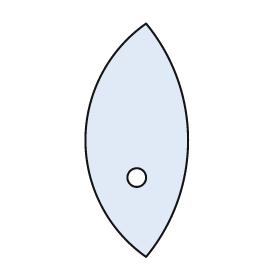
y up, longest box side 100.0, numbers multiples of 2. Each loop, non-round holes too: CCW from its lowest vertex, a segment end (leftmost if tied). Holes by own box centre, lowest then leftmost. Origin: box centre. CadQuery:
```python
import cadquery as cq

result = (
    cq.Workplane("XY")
    .moveTo(4.0, -50.0)
    .threePointArc((22.0, 0.0), (4.0, 50.0))
    .threePointArc((-22.0, 0.0), (4.0, -50.0))
    .close()
    .moveTo(0.0, -16.0)
    .circle(4.0)
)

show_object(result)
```